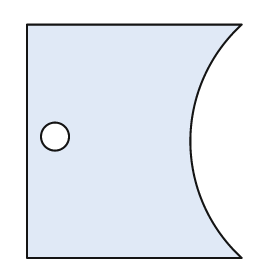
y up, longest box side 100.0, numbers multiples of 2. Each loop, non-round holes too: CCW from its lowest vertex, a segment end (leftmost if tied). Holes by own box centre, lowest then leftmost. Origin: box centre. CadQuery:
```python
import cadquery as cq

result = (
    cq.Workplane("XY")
    .moveTo(-46.0, -50.0)
    .lineTo(46.0, -50.0)
    .threePointArc((24.0, 0.0), (46.0, 50.0))
    .lineTo(-46.0, 50.0)
    .close()
    .moveTo(-34.0, 2.0)
    .circle(6.0)
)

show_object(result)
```